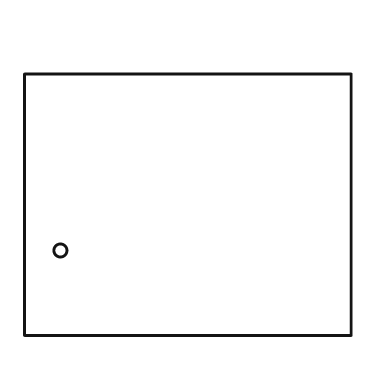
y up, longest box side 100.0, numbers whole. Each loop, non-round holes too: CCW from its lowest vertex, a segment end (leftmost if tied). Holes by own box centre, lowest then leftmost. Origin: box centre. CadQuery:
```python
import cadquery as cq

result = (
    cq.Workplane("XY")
    .moveTo(-50.0, -40.0)
    .lineTo(50.0, -40.0)
    .lineTo(50.0, 40.0)
    .lineTo(-50.0, 40.0)
    .close()
    .moveTo(-39.0, -14.0)
    .circle(2.0)
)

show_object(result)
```